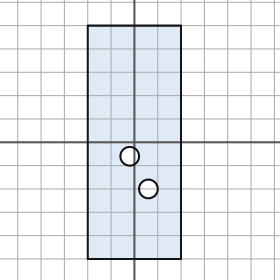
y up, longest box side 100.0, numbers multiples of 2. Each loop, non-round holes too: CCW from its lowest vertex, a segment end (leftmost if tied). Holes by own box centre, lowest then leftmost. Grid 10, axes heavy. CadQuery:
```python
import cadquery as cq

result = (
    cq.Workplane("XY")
    .moveTo(-20.0, -50.0)
    .lineTo(20.0, -50.0)
    .lineTo(20.0, 50.0)
    .lineTo(-20.0, 50.0)
    .close()
    .moveTo(6.0, -20.0)
    .circle(4.0)
    .moveTo(-2.0, -6.0)
    .circle(4.0)
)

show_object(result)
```